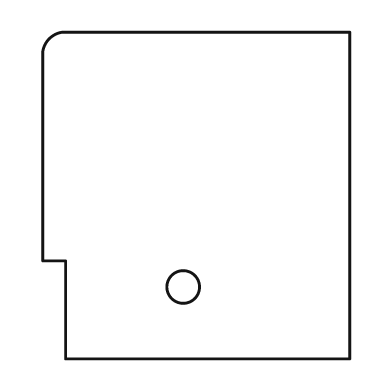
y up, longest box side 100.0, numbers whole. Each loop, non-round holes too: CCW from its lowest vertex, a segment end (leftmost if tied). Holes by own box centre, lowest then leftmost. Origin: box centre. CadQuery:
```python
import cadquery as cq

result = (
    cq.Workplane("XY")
    .moveTo(-40.0, -50.0)
    .lineTo(47.0, -50.0)
    .lineTo(47.0, 50.0)
    .lineTo(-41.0, 50.0)
    .threePointArc((-45.0, 48.0), (-47.0, 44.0))
    .lineTo(-47.0, -20.0)
    .lineTo(-40.0, -20.0)
    .close()
    .moveTo(-4.0, -28.0)
    .circle(5.0)
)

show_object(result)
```